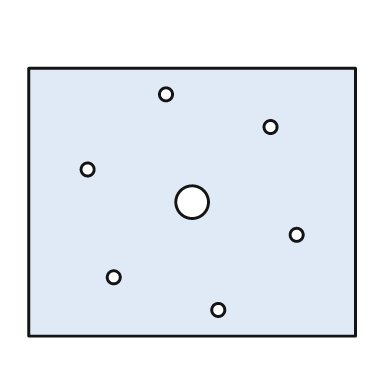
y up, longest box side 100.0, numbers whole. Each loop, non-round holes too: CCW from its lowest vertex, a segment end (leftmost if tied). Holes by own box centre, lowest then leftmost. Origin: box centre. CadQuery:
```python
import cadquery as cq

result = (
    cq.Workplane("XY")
    .moveTo(-50.0, -41.0)
    .lineTo(50.0, -41.0)
    .lineTo(50.0, 41.0)
    .lineTo(-50.0, 41.0)
    .close()
    .moveTo(8.0, -33.0)
    .circle(2.0)
    .moveTo(-24.0, -23.0)
    .circle(2.0)
    .moveTo(32.0, -10.0)
    .circle(2.0)
    .moveTo(0.0, 0.0)
    .circle(5.0)
    .moveTo(-32.0, 10.0)
    .circle(2.0)
    .moveTo(24.0, 23.0)
    .circle(2.0)
    .moveTo(-8.0, 33.0)
    .circle(2.0)
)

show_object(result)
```